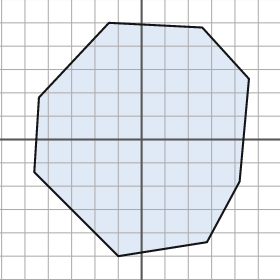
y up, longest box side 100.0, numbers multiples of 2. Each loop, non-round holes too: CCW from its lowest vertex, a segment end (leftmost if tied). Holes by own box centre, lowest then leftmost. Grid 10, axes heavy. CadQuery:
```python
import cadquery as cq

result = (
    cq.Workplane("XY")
    .moveTo(-10.0, -50.0)
    .lineTo(28.0, -44.0)
    .lineTo(42.0, -18.0)
    .lineTo(46.0, 26.0)
    .lineTo(26.0, 48.0)
    .lineTo(-14.0, 50.0)
    .lineTo(-44.0, 18.0)
    .lineTo(-46.0, -14.0)
    .close()
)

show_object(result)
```